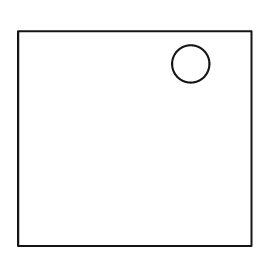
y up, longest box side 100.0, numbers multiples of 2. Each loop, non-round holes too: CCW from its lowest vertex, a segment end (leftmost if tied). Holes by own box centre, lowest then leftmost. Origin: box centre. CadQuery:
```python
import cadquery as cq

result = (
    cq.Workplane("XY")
    .moveTo(-50.0, -46.0)
    .lineTo(50.0, -46.0)
    .lineTo(50.0, 46.0)
    .lineTo(-50.0, 46.0)
    .close()
    .moveTo(24.0, 32.0)
    .circle(8.0)
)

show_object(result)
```